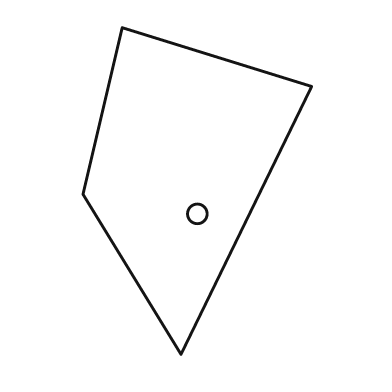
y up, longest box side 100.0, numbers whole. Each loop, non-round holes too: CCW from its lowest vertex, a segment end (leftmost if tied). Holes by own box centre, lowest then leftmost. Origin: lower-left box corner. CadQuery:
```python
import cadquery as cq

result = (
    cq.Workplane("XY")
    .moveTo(30.0, 0.0)
    .lineTo(70.0, 82.0)
    .lineTo(12.0, 100.0)
    .lineTo(0.0, 49.0)
    .close()
    .moveTo(35.0, 43.0)
    .circle(3.0)
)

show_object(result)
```